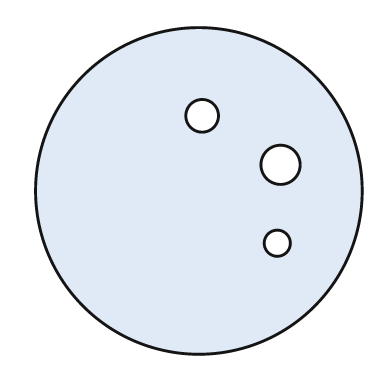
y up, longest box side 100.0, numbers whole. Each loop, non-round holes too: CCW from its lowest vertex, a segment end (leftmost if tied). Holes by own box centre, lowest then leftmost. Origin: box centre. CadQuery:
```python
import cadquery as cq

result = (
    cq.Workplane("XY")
    .moveTo(0.0, 0.0)
    .circle(50.0)
    .moveTo(24.0, -16.0)
    .circle(4.0)
    .moveTo(25.0, 8.0)
    .circle(6.0)
    .moveTo(1.0, 23.0)
    .circle(5.0)
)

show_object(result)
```